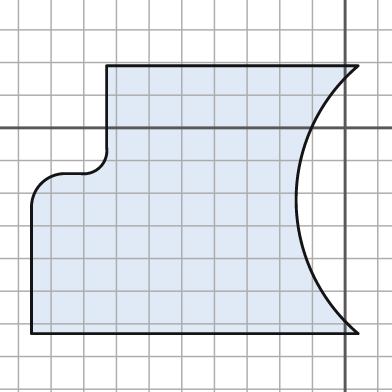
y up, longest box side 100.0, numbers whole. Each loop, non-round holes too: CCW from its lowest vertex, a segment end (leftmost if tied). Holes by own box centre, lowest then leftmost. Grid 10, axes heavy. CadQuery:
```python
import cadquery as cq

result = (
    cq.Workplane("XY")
    .moveTo(-96.0, -63.0)
    .lineTo(4.0, -63.0)
    .threePointArc((-15.0, -22.0), (4.0, 19.0))
    .lineTo(-73.0, 19.0)
    .lineTo(-73.0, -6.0)
    .threePointArc((-75.0, -12.0), (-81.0, -14.0))
    .lineTo(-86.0, -14.0)
    .threePointArc((-93.0, -17.0), (-96.0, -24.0))
    .close()
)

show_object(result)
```